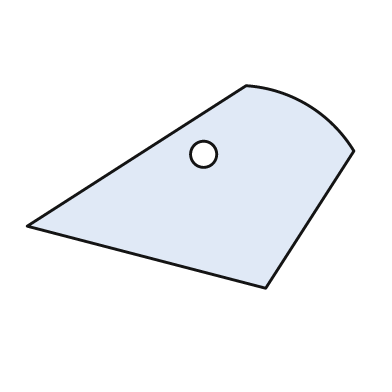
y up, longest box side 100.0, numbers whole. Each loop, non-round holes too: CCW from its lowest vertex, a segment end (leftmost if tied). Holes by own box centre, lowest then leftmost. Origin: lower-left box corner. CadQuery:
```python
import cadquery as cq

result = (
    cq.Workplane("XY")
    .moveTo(73.0, 0.0)
    .lineTo(100.0, 42.0)
    .threePointArc((86.0, 56.0), (67.0, 62.0))
    .lineTo(0.0, 19.0)
    .close()
    .moveTo(54.0, 41.0)
    .circle(4.0)
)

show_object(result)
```